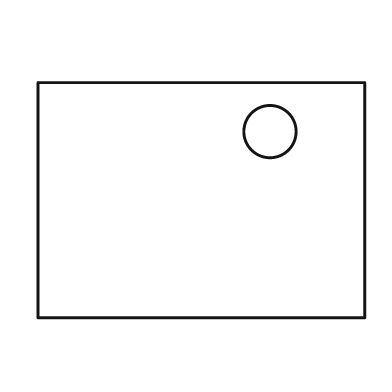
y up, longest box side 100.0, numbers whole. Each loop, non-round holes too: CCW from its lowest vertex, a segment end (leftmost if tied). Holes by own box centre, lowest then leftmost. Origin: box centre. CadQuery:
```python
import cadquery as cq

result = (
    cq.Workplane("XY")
    .moveTo(-50.0, -36.0)
    .lineTo(50.0, -36.0)
    .lineTo(50.0, 36.0)
    .lineTo(-50.0, 36.0)
    .close()
    .moveTo(21.0, 21.0)
    .circle(8.0)
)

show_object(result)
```